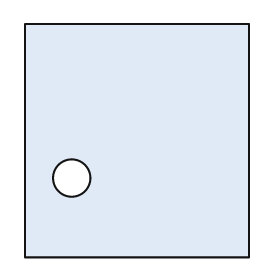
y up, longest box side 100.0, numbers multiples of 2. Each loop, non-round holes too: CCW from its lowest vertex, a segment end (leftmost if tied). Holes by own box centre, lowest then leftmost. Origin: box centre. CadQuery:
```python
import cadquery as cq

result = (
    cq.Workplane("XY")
    .moveTo(-48.0, -50.0)
    .lineTo(48.0, -50.0)
    .lineTo(48.0, 50.0)
    .lineTo(-48.0, 50.0)
    .close()
    .moveTo(-28.0, -16.0)
    .circle(8.0)
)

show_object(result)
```